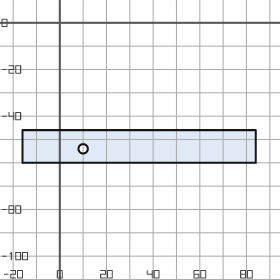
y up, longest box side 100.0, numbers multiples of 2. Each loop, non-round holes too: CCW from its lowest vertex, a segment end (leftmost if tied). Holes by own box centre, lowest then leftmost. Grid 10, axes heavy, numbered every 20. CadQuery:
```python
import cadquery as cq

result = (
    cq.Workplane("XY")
    .moveTo(-16.0, -60.0)
    .lineTo(84.0, -60.0)
    .lineTo(84.0, -46.0)
    .lineTo(-16.0, -46.0)
    .close()
    .moveTo(10.0, -54.0)
    .circle(2.0)
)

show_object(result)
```